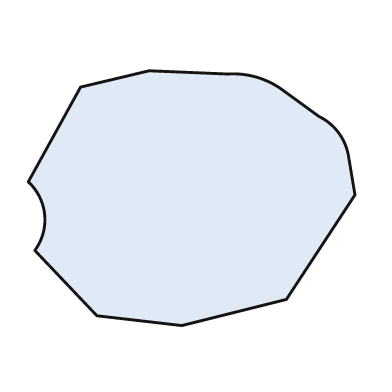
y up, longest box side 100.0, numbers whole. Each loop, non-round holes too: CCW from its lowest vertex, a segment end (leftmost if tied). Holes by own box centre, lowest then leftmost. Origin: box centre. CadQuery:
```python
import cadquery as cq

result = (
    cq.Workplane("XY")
    .moveTo(-3.0, -39.0)
    .lineTo(29.0, -31.0)
    .lineTo(50.0, 1.0)
    .lineTo(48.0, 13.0)
    .threePointArc((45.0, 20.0), (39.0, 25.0))
    .lineTo(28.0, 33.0)
    .threePointArc((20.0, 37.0), (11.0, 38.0))
    .lineTo(-13.0, 39.0)
    .lineTo(-34.0, 34.0)
    .lineTo(-50.0, 5.0)
    .threePointArc((-45.0, -5.0), (-48.0, -16.0))
    .lineTo(-29.0, -36.0)
    .close()
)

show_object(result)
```